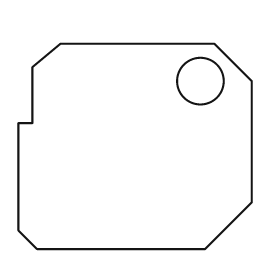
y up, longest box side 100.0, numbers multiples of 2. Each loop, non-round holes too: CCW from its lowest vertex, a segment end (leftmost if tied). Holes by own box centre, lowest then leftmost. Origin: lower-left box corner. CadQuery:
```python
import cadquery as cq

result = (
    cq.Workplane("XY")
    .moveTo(8.0, 0.0)
    .lineTo(80.0, 0.0)
    .lineTo(100.0, 20.0)
    .lineTo(100.0, 72.0)
    .lineTo(84.0, 88.0)
    .lineTo(18.0, 88.0)
    .lineTo(6.0, 78.0)
    .lineTo(6.0, 54.0)
    .lineTo(0.0, 54.0)
    .lineTo(0.0, 8.0)
    .close()
    .moveTo(78.0, 72.0)
    .circle(10.0)
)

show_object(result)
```